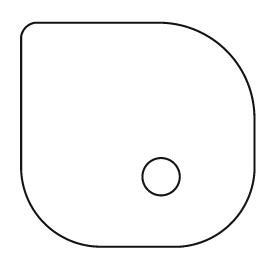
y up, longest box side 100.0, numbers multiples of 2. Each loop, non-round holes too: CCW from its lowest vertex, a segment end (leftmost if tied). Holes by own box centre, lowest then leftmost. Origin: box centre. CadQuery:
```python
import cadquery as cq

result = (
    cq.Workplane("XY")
    .moveTo(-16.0, -48.0)
    .lineTo(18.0, -48.0)
    .threePointArc((40.0, -38.0), (50.0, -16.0))
    .lineTo(50.0, 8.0)
    .threePointArc((38.0, 36.0), (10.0, 48.0))
    .lineTo(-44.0, 48.0)
    .threePointArc((-48.0, 46.0), (-50.0, 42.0))
    .lineTo(-50.0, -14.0)
    .threePointArc((-40.0, -38.0), (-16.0, -48.0))
    .close()
    .moveTo(10.0, -18.0)
    .circle(8.0)
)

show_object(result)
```